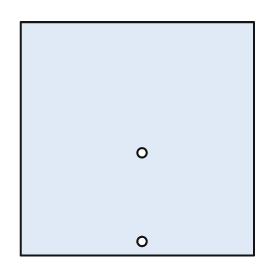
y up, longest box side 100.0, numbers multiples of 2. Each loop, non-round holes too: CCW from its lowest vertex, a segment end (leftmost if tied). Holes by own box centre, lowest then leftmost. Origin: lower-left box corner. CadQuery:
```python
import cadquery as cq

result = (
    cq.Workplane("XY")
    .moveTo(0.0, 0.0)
    .lineTo(100.0, 0.0)
    .lineTo(100.0, 100.0)
    .lineTo(0.0, 100.0)
    .close()
    .moveTo(52.0, 6.0)
    .circle(2.0)
    .moveTo(52.0, 44.0)
    .circle(2.0)
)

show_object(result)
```